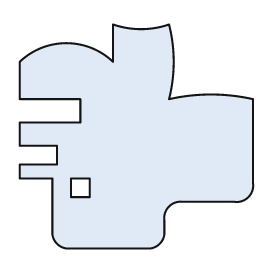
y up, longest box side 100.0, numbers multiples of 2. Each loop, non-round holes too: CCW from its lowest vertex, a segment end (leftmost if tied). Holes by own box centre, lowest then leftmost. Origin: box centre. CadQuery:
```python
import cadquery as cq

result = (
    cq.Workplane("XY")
    .moveTo(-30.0, -48.0)
    .lineTo(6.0, -48.0)
    .threePointArc((10.0, -46.0), (12.0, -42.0))
    .lineTo(12.0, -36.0)
    .threePointArc((14.0, -30.0), (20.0, -28.0))
    .lineTo(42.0, -28.0)
    .threePointArc((48.0, -26.0), (50.0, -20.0))
    .lineTo(50.0, 16.0)
    .threePointArc((32.0, 18.0), (14.0, 16.0))
    .threePointArc((16.0, 32.0), (14.0, 48.0))
    .threePointArc((2.0, 46.0), (-10.0, 48.0))
    .lineTo(-10.0, 32.0)
    .threePointArc((-30.0, 40.0), (-50.0, 32.0))
    .lineTo(-50.0, 16.0)
    .lineTo(-24.0, 16.0)
    .lineTo(-24.0, 6.0)
    .lineTo(-50.0, 6.0)
    .lineTo(-50.0, -4.0)
    .lineTo(-34.0, -4.0)
    .lineTo(-34.0, -12.0)
    .lineTo(-50.0, -12.0)
    .lineTo(-50.0, -18.0)
    .lineTo(-36.0, -18.0)
    .lineTo(-36.0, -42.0)
    .threePointArc((-34.0, -46.0), (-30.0, -48.0))
    .close()
    .moveTo(-28.0, -26.0)
    .lineTo(-20.0, -26.0)
    .lineTo(-20.0, -18.0)
    .lineTo(-28.0, -18.0)
    .close()
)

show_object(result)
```